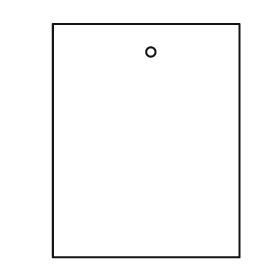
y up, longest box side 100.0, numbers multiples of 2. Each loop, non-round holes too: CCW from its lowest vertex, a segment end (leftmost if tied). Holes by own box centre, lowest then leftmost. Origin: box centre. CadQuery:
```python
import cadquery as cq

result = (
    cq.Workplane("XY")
    .moveTo(-40.0, -50.0)
    .lineTo(40.0, -50.0)
    .lineTo(40.0, 50.0)
    .lineTo(-40.0, 50.0)
    .close()
    .moveTo(2.0, 38.0)
    .circle(2.0)
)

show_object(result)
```